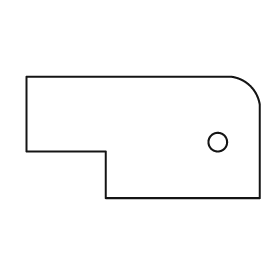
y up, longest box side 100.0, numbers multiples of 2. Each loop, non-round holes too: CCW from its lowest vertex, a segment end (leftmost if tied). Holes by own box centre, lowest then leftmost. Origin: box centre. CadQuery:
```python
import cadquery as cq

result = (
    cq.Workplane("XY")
    .moveTo(-16.0, -26.0)
    .lineTo(50.0, -26.0)
    .lineTo(50.0, 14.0)
    .threePointArc((46.0, 22.0), (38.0, 26.0))
    .lineTo(-50.0, 26.0)
    .lineTo(-50.0, -6.0)
    .lineTo(-16.0, -6.0)
    .close()
    .moveTo(32.0, -2.0)
    .circle(4.0)
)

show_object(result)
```